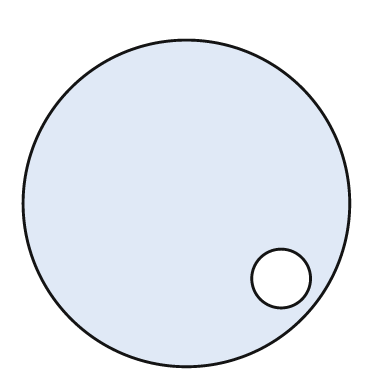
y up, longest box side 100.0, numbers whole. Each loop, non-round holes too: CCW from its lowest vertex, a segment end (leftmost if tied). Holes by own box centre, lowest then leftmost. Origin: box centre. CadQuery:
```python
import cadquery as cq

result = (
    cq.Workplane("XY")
    .moveTo(0.0, 0.0)
    .circle(50.0)
    .moveTo(29.0, -23.0)
    .circle(9.0)
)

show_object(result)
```